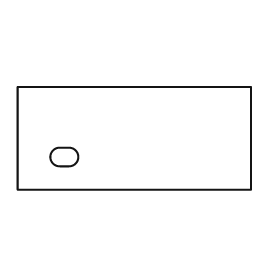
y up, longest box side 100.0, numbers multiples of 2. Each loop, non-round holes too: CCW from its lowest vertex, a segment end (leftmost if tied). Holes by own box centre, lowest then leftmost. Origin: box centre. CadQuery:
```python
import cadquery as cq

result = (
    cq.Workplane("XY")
    .moveTo(-50.0, -22.0)
    .lineTo(50.0, -22.0)
    .lineTo(50.0, 22.0)
    .lineTo(-50.0, 22.0)
    .close()
    .moveTo(-32.0, -12.0)
    .lineTo(-28.0, -12.0)
    .threePointArc((-24.0, -8.0), (-28.0, -4.0))
    .lineTo(-32.0, -4.0)
    .threePointArc((-36.0, -8.0), (-32.0, -12.0))
    .close()
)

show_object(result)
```